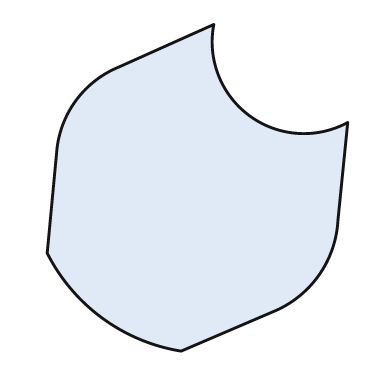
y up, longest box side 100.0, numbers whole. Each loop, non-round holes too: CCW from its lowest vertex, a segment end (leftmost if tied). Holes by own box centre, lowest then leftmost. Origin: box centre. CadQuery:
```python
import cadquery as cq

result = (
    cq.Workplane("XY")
    .moveTo(-5.0, -50.0)
    .lineTo(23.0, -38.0)
    .threePointArc((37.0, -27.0), (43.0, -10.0))
    .lineTo(46.0, 20.0)
    .threePointArc((16.0, 22.0), (5.0, 50.0))
    .lineTo(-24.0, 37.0)
    .threePointArc((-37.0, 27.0), (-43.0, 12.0))
    .lineTo(-46.0, -20.0)
    .threePointArc((-29.0, -40.0), (-5.0, -50.0))
    .close()
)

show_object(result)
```